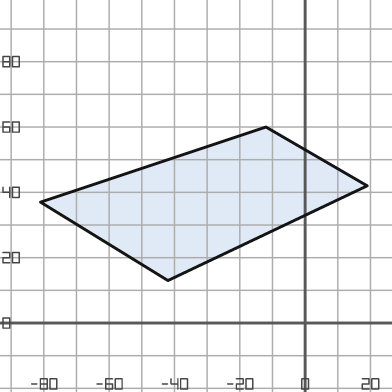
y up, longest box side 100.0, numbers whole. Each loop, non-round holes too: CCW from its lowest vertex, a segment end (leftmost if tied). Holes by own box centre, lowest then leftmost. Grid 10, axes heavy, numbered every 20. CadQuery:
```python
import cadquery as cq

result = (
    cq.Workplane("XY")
    .moveTo(-42.0, 13.0)
    .lineTo(19.0, 42.0)
    .lineTo(-12.0, 60.0)
    .lineTo(-81.0, 37.0)
    .close()
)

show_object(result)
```